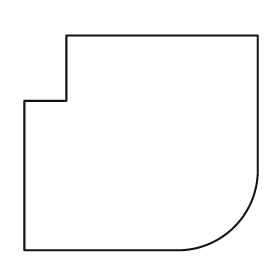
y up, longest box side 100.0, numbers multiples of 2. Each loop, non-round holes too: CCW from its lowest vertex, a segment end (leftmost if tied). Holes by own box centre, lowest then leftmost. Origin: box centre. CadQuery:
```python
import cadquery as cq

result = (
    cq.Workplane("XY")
    .moveTo(-50.0, -46.0)
    .lineTo(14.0, -46.0)
    .threePointArc((40.0, -36.0), (50.0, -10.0))
    .lineTo(50.0, 46.0)
    .lineTo(-32.0, 46.0)
    .lineTo(-32.0, 18.0)
    .lineTo(-50.0, 18.0)
    .close()
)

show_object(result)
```